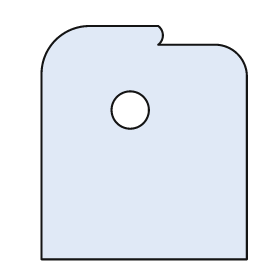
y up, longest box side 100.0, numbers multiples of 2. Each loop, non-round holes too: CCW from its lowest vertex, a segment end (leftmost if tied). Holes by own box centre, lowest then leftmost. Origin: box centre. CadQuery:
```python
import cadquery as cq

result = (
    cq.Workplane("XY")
    .moveTo(-44.0, -50.0)
    .lineTo(44.0, -50.0)
    .lineTo(44.0, 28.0)
    .threePointArc((40.0, 38.0), (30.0, 42.0))
    .lineTo(6.0, 42.0)
    .threePointArc((8.0, 46.0), (6.0, 50.0))
    .lineTo(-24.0, 50.0)
    .threePointArc((-38.0, 44.0), (-44.0, 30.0))
    .close()
    .moveTo(-6.0, 14.0)
    .circle(8.0)
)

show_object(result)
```